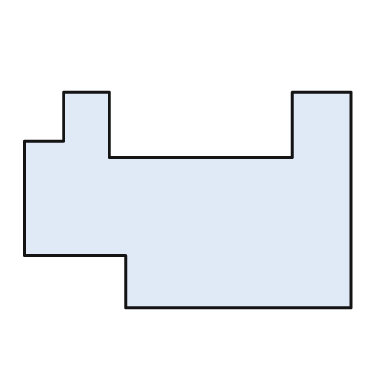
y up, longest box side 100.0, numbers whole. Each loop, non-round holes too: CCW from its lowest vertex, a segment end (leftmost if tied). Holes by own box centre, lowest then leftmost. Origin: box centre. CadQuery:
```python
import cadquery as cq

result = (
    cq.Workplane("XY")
    .moveTo(-19.0, -33.0)
    .lineTo(50.0, -33.0)
    .lineTo(50.0, 33.0)
    .lineTo(32.0, 33.0)
    .lineTo(32.0, 13.0)
    .lineTo(-24.0, 13.0)
    .lineTo(-24.0, 33.0)
    .lineTo(-38.0, 33.0)
    .lineTo(-38.0, 18.0)
    .lineTo(-50.0, 18.0)
    .lineTo(-50.0, -17.0)
    .lineTo(-19.0, -17.0)
    .close()
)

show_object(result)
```